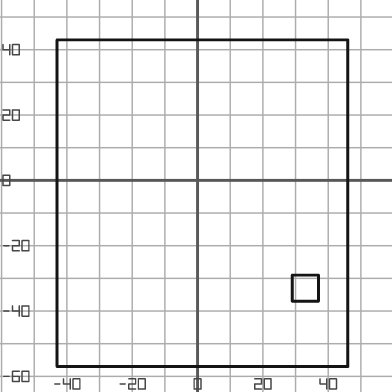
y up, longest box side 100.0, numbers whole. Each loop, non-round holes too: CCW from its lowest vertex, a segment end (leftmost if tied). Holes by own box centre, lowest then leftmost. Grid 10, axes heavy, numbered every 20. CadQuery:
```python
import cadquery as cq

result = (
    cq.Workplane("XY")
    .moveTo(-43.0, -57.0)
    .lineTo(46.0, -57.0)
    .lineTo(46.0, 43.0)
    .lineTo(-43.0, 43.0)
    .close()
    .moveTo(29.0, -37.0)
    .lineTo(37.0, -37.0)
    .lineTo(37.0, -29.0)
    .lineTo(29.0, -29.0)
    .close()
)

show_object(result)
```